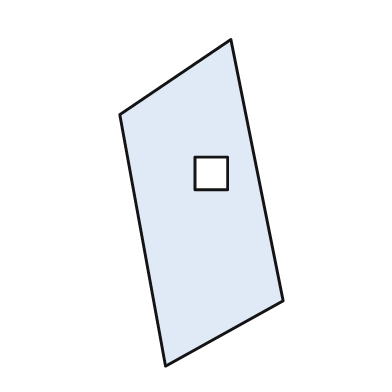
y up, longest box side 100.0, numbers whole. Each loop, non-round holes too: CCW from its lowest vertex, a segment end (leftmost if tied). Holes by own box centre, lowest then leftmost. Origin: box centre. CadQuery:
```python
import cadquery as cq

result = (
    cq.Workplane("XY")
    .moveTo(-11.0, -50.0)
    .lineTo(25.0, -30.0)
    .lineTo(9.0, 50.0)
    .lineTo(-25.0, 27.0)
    .close()
    .moveTo(-2.0, 4.0)
    .lineTo(8.0, 4.0)
    .lineTo(8.0, 14.0)
    .lineTo(-2.0, 14.0)
    .close()
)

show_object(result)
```